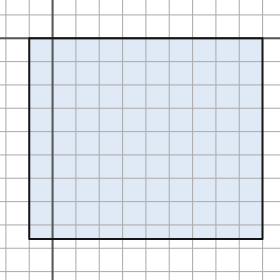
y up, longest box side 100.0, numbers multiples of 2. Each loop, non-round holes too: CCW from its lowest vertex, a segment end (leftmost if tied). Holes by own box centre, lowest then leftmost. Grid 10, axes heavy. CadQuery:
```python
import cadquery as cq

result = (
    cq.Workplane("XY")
    .moveTo(-10.0, -86.0)
    .lineTo(90.0, -86.0)
    .lineTo(90.0, 0.0)
    .lineTo(-10.0, 0.0)
    .close()
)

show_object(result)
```